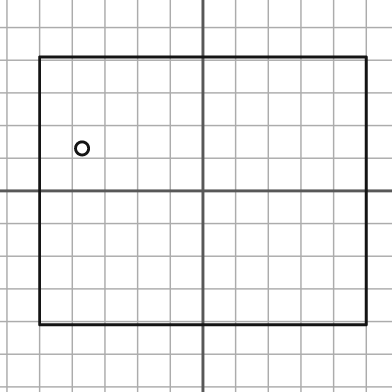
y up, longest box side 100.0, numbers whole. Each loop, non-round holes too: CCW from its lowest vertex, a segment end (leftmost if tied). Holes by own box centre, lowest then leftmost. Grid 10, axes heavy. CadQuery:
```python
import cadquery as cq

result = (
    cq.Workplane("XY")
    .moveTo(-50.0, -41.0)
    .lineTo(50.0, -41.0)
    .lineTo(50.0, 41.0)
    .lineTo(-50.0, 41.0)
    .close()
    .moveTo(-37.0, 13.0)
    .circle(2.0)
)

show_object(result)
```